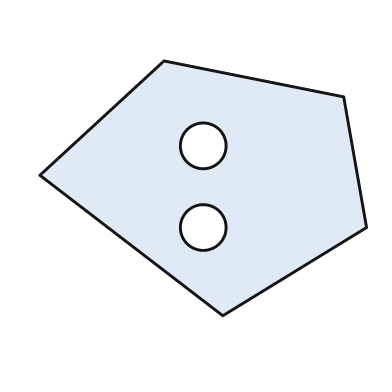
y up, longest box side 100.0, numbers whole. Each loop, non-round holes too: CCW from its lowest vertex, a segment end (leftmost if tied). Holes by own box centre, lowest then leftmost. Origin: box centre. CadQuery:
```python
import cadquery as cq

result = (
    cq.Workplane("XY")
    .moveTo(6.0, -39.0)
    .lineTo(50.0, -12.0)
    .lineTo(43.0, 28.0)
    .lineTo(-12.0, 39.0)
    .lineTo(-50.0, 4.0)
    .close()
    .moveTo(0.0, -12.0)
    .circle(7.0)
    .moveTo(0.0, 13.0)
    .circle(7.0)
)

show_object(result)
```